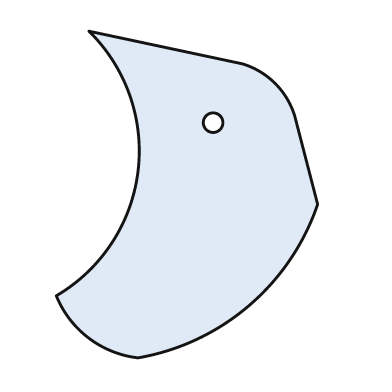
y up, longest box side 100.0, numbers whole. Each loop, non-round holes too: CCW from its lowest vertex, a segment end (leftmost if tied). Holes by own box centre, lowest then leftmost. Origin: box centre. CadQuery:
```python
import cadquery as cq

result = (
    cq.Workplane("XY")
    .moveTo(-15.0, -50.0)
    .threePointArc((19.0, -34.0), (40.0, -3.0))
    .lineTo(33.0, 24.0)
    .threePointArc((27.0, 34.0), (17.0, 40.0))
    .lineTo(-30.0, 50.0)
    .threePointArc((-15.0, 7.0), (-40.0, -31.0))
    .threePointArc((-30.0, -44.0), (-15.0, -50.0))
    .close()
    .moveTo(8.0, 22.0)
    .circle(3.0)
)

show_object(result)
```